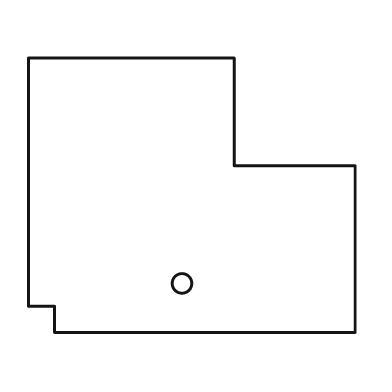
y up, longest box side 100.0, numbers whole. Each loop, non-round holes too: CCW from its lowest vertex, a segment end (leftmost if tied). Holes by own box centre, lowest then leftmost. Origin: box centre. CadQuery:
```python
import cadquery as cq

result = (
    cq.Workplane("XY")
    .moveTo(-42.0, -42.0)
    .lineTo(50.0, -42.0)
    .lineTo(50.0, 9.0)
    .lineTo(13.0, 9.0)
    .lineTo(13.0, 42.0)
    .lineTo(-50.0, 42.0)
    .lineTo(-50.0, -34.0)
    .lineTo(-42.0, -34.0)
    .close()
    .moveTo(-3.0, -27.0)
    .circle(3.0)
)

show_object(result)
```